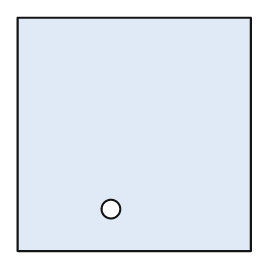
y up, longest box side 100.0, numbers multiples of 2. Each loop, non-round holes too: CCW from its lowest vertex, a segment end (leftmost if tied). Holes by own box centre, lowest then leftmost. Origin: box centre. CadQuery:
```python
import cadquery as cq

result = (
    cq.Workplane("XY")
    .moveTo(-50.0, -50.0)
    .lineTo(50.0, -50.0)
    .lineTo(50.0, 50.0)
    .lineTo(-50.0, 50.0)
    .close()
    .moveTo(-10.0, -32.0)
    .circle(4.0)
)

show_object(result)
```